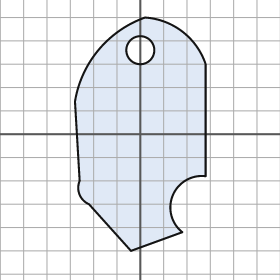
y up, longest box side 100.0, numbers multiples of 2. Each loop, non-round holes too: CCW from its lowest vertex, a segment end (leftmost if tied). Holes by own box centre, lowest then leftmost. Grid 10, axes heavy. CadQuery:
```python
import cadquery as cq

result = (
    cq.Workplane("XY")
    .moveTo(-4.0, -50.0)
    .lineTo(18.0, -42.0)
    .threePointArc((14.0, -26.0), (28.0, -18.0))
    .lineTo(28.0, 30.0)
    .threePointArc((18.0, 44.0), (2.0, 50.0))
    .threePointArc((-18.0, 36.0), (-28.0, 14.0))
    .lineTo(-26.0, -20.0)
    .threePointArc((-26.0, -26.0), (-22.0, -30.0))
    .close()
    .moveTo(0.0, 36.0)
    .circle(6.0)
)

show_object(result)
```